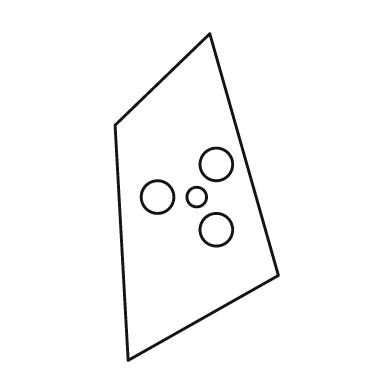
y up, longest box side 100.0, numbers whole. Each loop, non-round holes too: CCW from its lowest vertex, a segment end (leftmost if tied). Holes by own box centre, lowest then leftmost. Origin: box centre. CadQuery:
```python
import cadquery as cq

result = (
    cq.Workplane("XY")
    .moveTo(-21.0, -50.0)
    .lineTo(25.0, -24.0)
    .lineTo(4.0, 50.0)
    .lineTo(-25.0, 22.0)
    .close()
    .moveTo(6.0, -10.0)
    .circle(5.0)
    .moveTo(-12.0, 0.0)
    .circle(5.0)
    .moveTo(0.0, 0.0)
    .circle(3.0)
    .moveTo(6.0, 10.0)
    .circle(5.0)
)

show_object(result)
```